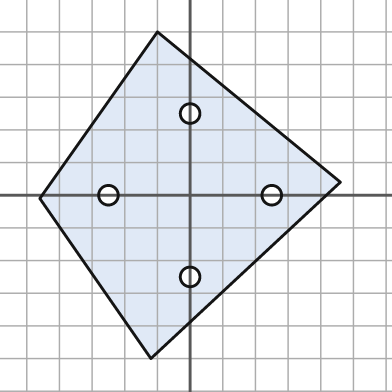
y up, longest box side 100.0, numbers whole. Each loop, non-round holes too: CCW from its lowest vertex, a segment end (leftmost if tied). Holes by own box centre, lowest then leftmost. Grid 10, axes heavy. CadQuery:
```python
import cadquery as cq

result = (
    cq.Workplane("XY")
    .moveTo(-12.0, -50.0)
    .lineTo(46.0, 4.0)
    .lineTo(-10.0, 50.0)
    .lineTo(-46.0, -1.0)
    .close()
    .moveTo(0.0, -25.0)
    .circle(3.0)
    .moveTo(-25.0, 0.0)
    .circle(3.0)
    .moveTo(25.0, 0.0)
    .circle(3.0)
    .moveTo(0.0, 25.0)
    .circle(3.0)
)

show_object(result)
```